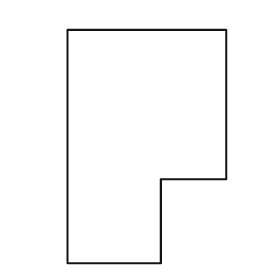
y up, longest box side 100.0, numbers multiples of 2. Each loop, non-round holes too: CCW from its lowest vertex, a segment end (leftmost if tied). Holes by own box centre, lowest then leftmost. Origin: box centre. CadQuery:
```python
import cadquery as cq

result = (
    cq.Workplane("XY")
    .moveTo(-34.0, -50.0)
    .lineTo(6.0, -50.0)
    .lineTo(6.0, -14.0)
    .lineTo(34.0, -14.0)
    .lineTo(34.0, 50.0)
    .lineTo(-34.0, 50.0)
    .close()
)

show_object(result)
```